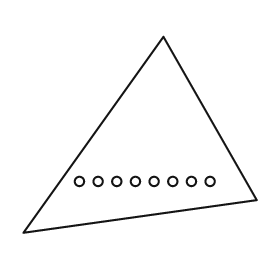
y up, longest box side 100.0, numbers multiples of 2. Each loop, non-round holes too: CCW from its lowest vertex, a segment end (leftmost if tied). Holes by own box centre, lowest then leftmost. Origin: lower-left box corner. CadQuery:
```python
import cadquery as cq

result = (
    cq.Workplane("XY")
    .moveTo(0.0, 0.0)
    .lineTo(100.0, 14.0)
    .lineTo(60.0, 84.0)
    .close()
    .moveTo(24.0, 22.0)
    .circle(2.0)
    .moveTo(32.0, 22.0)
    .circle(2.0)
    .moveTo(40.0, 22.0)
    .circle(2.0)
    .moveTo(48.0, 22.0)
    .circle(2.0)
    .moveTo(56.0, 22.0)
    .circle(2.0)
    .moveTo(64.0, 22.0)
    .circle(2.0)
    .moveTo(72.0, 22.0)
    .circle(2.0)
    .moveTo(80.0, 22.0)
    .circle(2.0)
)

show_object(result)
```